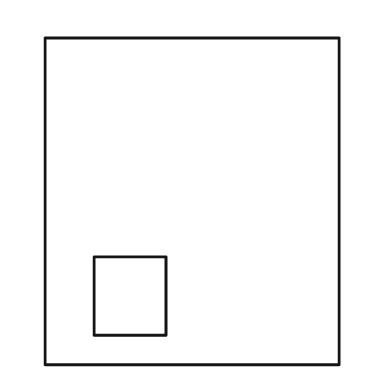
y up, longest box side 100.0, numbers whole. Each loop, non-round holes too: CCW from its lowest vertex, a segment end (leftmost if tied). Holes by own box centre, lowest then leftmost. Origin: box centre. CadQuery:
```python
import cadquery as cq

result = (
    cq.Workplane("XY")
    .moveTo(-45.0, -50.0)
    .lineTo(45.0, -50.0)
    .lineTo(45.0, 50.0)
    .lineTo(-45.0, 50.0)
    .close()
    .moveTo(-30.0, -41.0)
    .lineTo(-8.0, -41.0)
    .lineTo(-8.0, -17.0)
    .lineTo(-30.0, -17.0)
    .close()
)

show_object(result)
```